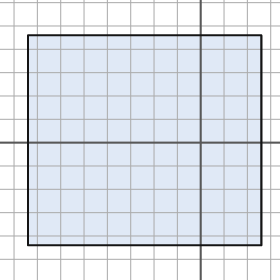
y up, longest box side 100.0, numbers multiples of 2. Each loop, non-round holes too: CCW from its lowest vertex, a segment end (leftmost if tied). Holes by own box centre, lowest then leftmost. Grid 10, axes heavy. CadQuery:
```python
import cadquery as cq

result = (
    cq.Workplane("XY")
    .moveTo(-74.0, -44.0)
    .lineTo(26.0, -44.0)
    .lineTo(26.0, 46.0)
    .lineTo(-74.0, 46.0)
    .close()
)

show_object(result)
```